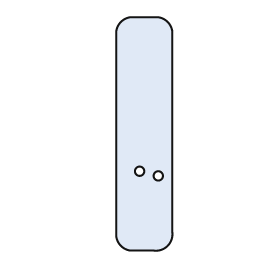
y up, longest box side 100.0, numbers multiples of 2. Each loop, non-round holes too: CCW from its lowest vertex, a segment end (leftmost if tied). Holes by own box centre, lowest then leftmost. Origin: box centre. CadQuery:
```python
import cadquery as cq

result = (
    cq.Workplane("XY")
    .moveTo(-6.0, -50.0)
    .lineTo(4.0, -50.0)
    .threePointArc((10.0, -48.0), (12.0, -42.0))
    .lineTo(12.0, 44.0)
    .threePointArc((10.0, 48.0), (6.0, 50.0))
    .lineTo(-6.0, 50.0)
    .threePointArc((-10.0, 48.0), (-12.0, 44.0))
    .lineTo(-12.0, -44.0)
    .threePointArc((-10.0, -48.0), (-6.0, -50.0))
    .close()
    .moveTo(6.0, -18.0)
    .circle(2.0)
    .moveTo(-2.0, -16.0)
    .circle(2.0)
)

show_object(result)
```